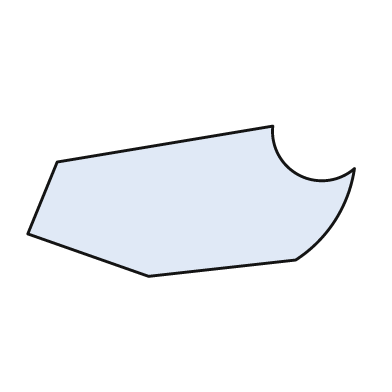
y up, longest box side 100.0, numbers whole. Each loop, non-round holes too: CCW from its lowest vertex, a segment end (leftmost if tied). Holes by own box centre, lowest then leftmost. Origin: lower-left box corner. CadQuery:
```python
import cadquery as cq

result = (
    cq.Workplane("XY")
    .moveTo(37.0, 0.0)
    .lineTo(82.0, 5.0)
    .threePointArc((94.0, 17.0), (100.0, 33.0))
    .threePointArc((83.0, 31.0), (75.0, 46.0))
    .lineTo(9.0, 35.0)
    .lineTo(0.0, 13.0)
    .close()
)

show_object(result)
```